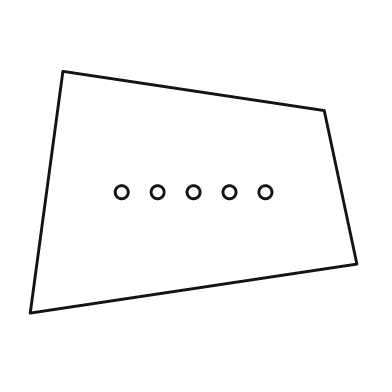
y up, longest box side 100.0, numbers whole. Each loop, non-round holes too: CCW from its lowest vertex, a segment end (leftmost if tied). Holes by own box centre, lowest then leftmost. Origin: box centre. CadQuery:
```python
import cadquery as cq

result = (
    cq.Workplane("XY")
    .moveTo(-50.0, -37.0)
    .lineTo(50.0, -22.0)
    .lineTo(40.0, 25.0)
    .lineTo(-40.0, 37.0)
    .close()
    .moveTo(-22.0, 0.0)
    .circle(2.0)
    .moveTo(-11.0, 0.0)
    .circle(2.0)
    .moveTo(0.0, 0.0)
    .circle(2.0)
    .moveTo(11.0, 0.0)
    .circle(2.0)
    .moveTo(22.0, 0.0)
    .circle(2.0)
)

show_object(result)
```